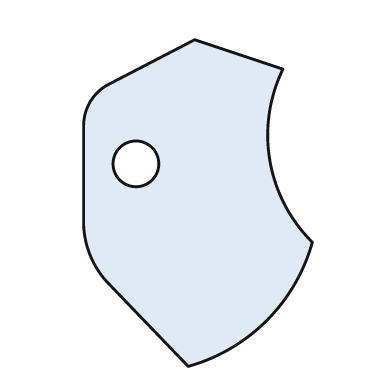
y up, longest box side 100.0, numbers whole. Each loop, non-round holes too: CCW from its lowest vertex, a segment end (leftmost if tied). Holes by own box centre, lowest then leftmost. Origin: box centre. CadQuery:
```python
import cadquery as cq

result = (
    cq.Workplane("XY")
    .moveTo(-3.0, -50.0)
    .threePointArc((21.0, -36.0), (35.0, -12.0))
    .threePointArc((22.0, 13.0), (26.0, 41.0))
    .lineTo(-1.0, 50.0)
    .lineTo(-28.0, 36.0)
    .threePointArc((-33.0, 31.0), (-35.0, 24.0))
    .lineTo(-35.0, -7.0)
    .threePointArc((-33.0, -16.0), (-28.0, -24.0))
    .close()
    .moveTo(-19.0, 12.0)
    .circle(7.0)
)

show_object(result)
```